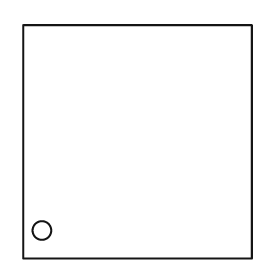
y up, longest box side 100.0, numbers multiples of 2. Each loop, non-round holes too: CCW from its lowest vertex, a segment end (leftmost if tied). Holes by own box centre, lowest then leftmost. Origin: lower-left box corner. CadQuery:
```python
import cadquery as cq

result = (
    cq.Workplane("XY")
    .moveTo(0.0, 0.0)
    .lineTo(98.0, 0.0)
    .lineTo(98.0, 100.0)
    .lineTo(0.0, 100.0)
    .close()
    .moveTo(8.0, 12.0)
    .circle(4.0)
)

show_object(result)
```